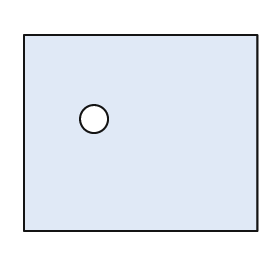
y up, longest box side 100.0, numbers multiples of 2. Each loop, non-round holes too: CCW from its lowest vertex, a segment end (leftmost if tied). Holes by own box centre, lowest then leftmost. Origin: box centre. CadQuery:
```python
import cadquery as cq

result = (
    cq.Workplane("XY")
    .moveTo(-50.0, -42.0)
    .lineTo(50.0, -42.0)
    .lineTo(50.0, 42.0)
    .lineTo(-50.0, 42.0)
    .close()
    .moveTo(-20.0, 6.0)
    .circle(6.0)
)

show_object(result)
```